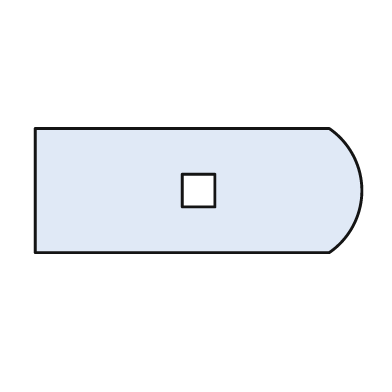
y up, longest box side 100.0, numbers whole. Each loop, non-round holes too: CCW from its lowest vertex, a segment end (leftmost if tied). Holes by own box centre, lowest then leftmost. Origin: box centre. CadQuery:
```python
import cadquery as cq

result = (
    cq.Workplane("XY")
    .moveTo(-50.0, -19.0)
    .lineTo(40.0, -19.0)
    .threePointArc((50.0, 0.0), (40.0, 19.0))
    .lineTo(-50.0, 19.0)
    .close()
    .moveTo(-5.0, -5.0)
    .lineTo(5.0, -5.0)
    .lineTo(5.0, 5.0)
    .lineTo(-5.0, 5.0)
    .close()
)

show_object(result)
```